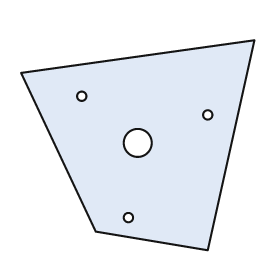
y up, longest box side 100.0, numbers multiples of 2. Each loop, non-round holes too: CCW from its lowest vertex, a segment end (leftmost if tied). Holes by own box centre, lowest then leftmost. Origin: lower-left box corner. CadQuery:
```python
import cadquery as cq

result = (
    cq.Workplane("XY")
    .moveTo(80.0, 0.0)
    .lineTo(100.0, 90.0)
    .lineTo(0.0, 76.0)
    .lineTo(32.0, 8.0)
    .close()
    .moveTo(46.0, 14.0)
    .circle(2.0)
    .moveTo(50.0, 46.0)
    .circle(6.0)
    .moveTo(80.0, 58.0)
    .circle(2.0)
    .moveTo(26.0, 66.0)
    .circle(2.0)
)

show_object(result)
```